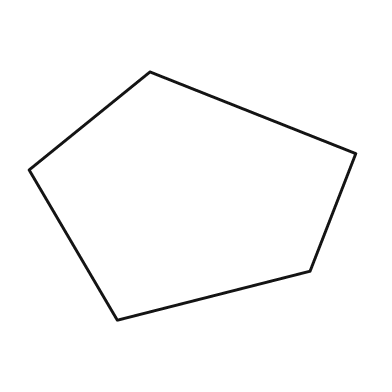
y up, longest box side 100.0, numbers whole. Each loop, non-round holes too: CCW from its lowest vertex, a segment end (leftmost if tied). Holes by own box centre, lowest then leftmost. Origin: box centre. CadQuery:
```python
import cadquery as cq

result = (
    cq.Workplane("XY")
    .moveTo(-23.0, -38.0)
    .lineTo(36.0, -23.0)
    .lineTo(50.0, 13.0)
    .lineTo(-13.0, 38.0)
    .lineTo(-50.0, 8.0)
    .close()
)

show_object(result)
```